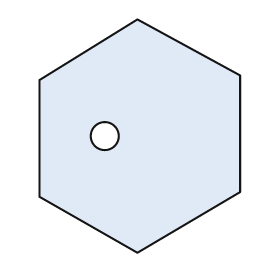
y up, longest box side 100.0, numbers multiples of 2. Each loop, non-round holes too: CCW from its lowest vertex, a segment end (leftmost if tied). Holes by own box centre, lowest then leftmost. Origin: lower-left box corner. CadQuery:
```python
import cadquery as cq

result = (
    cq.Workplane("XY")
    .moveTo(42.0, 0.0)
    .lineTo(86.0, 26.0)
    .lineTo(86.0, 76.0)
    .lineTo(42.0, 100.0)
    .lineTo(0.0, 74.0)
    .lineTo(0.0, 24.0)
    .close()
    .moveTo(28.0, 50.0)
    .circle(6.0)
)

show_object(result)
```